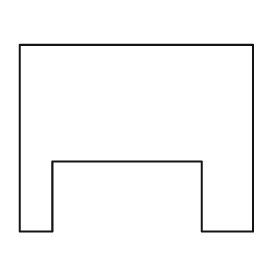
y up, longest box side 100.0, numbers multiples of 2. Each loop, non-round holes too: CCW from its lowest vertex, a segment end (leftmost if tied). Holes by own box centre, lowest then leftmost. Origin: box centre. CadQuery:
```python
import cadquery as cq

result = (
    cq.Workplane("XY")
    .moveTo(-50.0, -40.0)
    .lineTo(-36.0, -40.0)
    .lineTo(-36.0, -10.0)
    .lineTo(28.0, -10.0)
    .lineTo(28.0, -40.0)
    .lineTo(50.0, -40.0)
    .lineTo(50.0, 40.0)
    .lineTo(-50.0, 40.0)
    .close()
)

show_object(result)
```